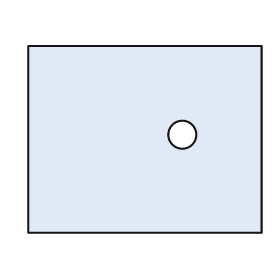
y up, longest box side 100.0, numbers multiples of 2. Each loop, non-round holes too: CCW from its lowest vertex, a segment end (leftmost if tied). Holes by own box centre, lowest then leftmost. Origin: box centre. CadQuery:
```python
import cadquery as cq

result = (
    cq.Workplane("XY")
    .moveTo(-50.0, -40.0)
    .lineTo(50.0, -40.0)
    .lineTo(50.0, 40.0)
    .lineTo(-50.0, 40.0)
    .close()
    .moveTo(16.0, 2.0)
    .circle(6.0)
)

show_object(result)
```